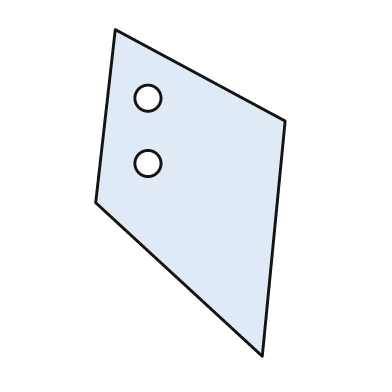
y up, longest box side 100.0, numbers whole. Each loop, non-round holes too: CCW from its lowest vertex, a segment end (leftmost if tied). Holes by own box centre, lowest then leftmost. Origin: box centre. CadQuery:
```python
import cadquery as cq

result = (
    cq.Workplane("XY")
    .moveTo(22.0, -50.0)
    .lineTo(29.0, 22.0)
    .lineTo(-23.0, 50.0)
    .lineTo(-29.0, -3.0)
    .close()
    .moveTo(-13.0, 9.0)
    .circle(4.0)
    .moveTo(-13.0, 29.0)
    .circle(4.0)
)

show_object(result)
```